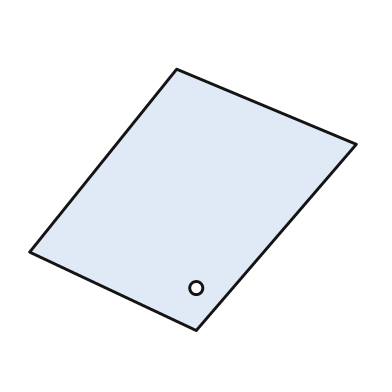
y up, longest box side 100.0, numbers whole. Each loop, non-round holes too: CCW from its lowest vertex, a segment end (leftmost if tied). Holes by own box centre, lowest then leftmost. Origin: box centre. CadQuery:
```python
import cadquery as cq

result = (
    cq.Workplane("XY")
    .moveTo(1.0, -40.0)
    .lineTo(50.0, 17.0)
    .lineTo(-5.0, 40.0)
    .lineTo(-50.0, -16.0)
    .close()
    .moveTo(1.0, -27.0)
    .circle(2.0)
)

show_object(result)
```